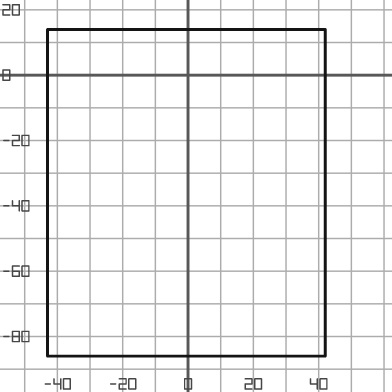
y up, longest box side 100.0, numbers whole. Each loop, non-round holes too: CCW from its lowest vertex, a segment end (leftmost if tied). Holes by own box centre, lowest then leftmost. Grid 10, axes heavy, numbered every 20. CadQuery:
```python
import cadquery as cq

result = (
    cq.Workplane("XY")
    .moveTo(-43.0, -86.0)
    .lineTo(42.0, -86.0)
    .lineTo(42.0, 14.0)
    .lineTo(-43.0, 14.0)
    .close()
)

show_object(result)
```